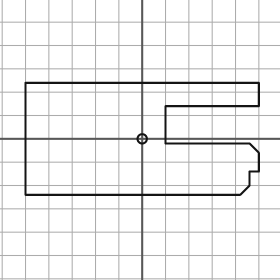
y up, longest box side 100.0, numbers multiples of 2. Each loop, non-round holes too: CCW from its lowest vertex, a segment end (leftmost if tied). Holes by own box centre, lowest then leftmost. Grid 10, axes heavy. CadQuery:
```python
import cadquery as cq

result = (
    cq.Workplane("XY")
    .moveTo(-50.0, -24.0)
    .lineTo(42.0, -24.0)
    .lineTo(46.0, -20.0)
    .lineTo(46.0, -14.0)
    .lineTo(50.0, -14.0)
    .lineTo(50.0, -6.0)
    .lineTo(46.0, -2.0)
    .lineTo(10.0, -2.0)
    .lineTo(10.0, 14.0)
    .lineTo(50.0, 14.0)
    .lineTo(50.0, 24.0)
    .lineTo(-50.0, 24.0)
    .close()
    .moveTo(0.0, 0.0)
    .circle(2.0)
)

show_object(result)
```